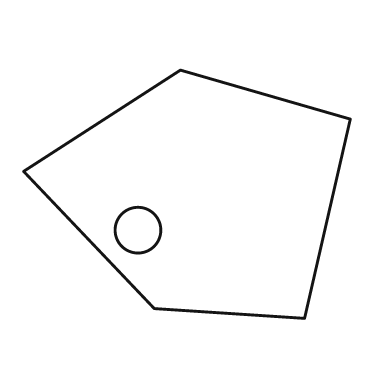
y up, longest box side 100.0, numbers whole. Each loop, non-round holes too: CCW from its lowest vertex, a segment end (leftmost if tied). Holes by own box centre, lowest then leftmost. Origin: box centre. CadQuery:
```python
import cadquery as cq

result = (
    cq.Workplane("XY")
    .moveTo(36.0, -38.0)
    .lineTo(50.0, 23.0)
    .lineTo(-2.0, 38.0)
    .lineTo(-50.0, 7.0)
    .lineTo(-10.0, -35.0)
    .close()
    .moveTo(-15.0, -11.0)
    .circle(7.0)
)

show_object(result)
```